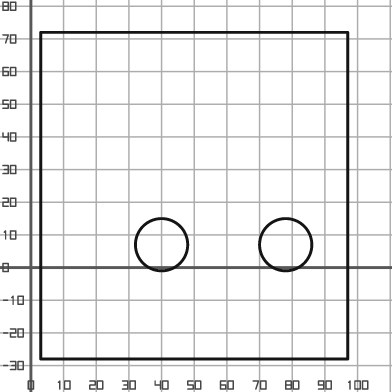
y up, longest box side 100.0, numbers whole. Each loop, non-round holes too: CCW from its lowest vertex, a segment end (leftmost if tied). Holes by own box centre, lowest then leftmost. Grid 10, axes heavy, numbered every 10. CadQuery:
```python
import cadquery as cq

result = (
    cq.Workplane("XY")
    .moveTo(3.0, -28.0)
    .lineTo(97.0, -28.0)
    .lineTo(97.0, 72.0)
    .lineTo(3.0, 72.0)
    .close()
    .moveTo(40.0, 7.0)
    .circle(8.0)
    .moveTo(78.0, 7.0)
    .circle(8.0)
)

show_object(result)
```